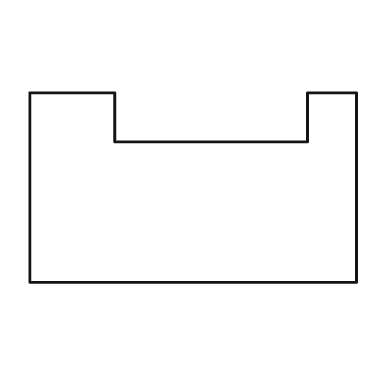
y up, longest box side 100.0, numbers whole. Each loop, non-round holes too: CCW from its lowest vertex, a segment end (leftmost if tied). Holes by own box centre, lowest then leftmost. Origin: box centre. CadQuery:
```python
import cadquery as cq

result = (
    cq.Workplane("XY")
    .moveTo(-50.0, -29.0)
    .lineTo(50.0, -29.0)
    .lineTo(50.0, 29.0)
    .lineTo(35.0, 29.0)
    .lineTo(35.0, 14.0)
    .lineTo(-24.0, 14.0)
    .lineTo(-24.0, 29.0)
    .lineTo(-50.0, 29.0)
    .close()
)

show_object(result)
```